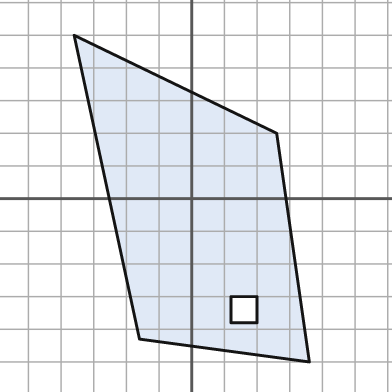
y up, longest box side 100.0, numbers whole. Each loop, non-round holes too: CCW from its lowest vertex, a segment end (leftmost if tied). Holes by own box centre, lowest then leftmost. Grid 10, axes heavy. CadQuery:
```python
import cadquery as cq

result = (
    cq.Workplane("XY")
    .moveTo(36.0, -50.0)
    .lineTo(26.0, 20.0)
    .lineTo(-36.0, 50.0)
    .lineTo(-16.0, -43.0)
    .close()
    .moveTo(12.0, -38.0)
    .lineTo(20.0, -38.0)
    .lineTo(20.0, -30.0)
    .lineTo(12.0, -30.0)
    .close()
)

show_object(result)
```